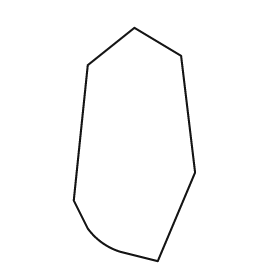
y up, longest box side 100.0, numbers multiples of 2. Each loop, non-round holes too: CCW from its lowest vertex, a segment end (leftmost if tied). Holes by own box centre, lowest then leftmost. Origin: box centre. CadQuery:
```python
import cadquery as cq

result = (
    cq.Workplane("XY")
    .moveTo(10.0, -50.0)
    .lineTo(26.0, -12.0)
    .lineTo(20.0, 38.0)
    .lineTo(0.0, 50.0)
    .lineTo(-20.0, 34.0)
    .lineTo(-26.0, -24.0)
    .lineTo(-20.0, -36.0)
    .threePointArc((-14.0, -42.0), (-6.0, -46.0))
    .close()
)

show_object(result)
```